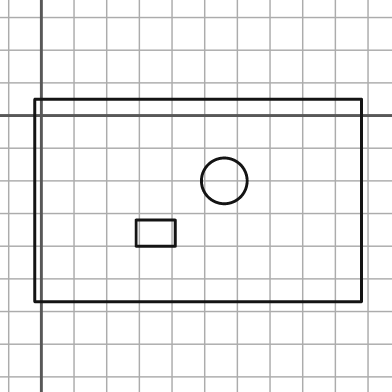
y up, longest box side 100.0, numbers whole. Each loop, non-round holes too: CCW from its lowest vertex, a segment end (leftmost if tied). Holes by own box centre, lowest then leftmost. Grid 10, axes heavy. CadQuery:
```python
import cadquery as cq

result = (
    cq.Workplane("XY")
    .moveTo(-2.0, -57.0)
    .lineTo(98.0, -57.0)
    .lineTo(98.0, 5.0)
    .lineTo(-2.0, 5.0)
    .close()
    .moveTo(29.0, -40.0)
    .lineTo(41.0, -40.0)
    .lineTo(41.0, -32.0)
    .lineTo(29.0, -32.0)
    .close()
    .moveTo(56.0, -20.0)
    .circle(7.0)
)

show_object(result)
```